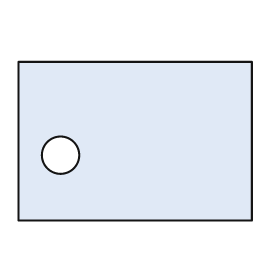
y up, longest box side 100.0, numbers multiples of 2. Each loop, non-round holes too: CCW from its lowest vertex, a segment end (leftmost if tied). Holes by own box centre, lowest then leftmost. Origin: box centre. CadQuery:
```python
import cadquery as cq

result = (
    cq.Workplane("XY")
    .moveTo(-50.0, -34.0)
    .lineTo(50.0, -34.0)
    .lineTo(50.0, 34.0)
    .lineTo(-50.0, 34.0)
    .close()
    .moveTo(-32.0, -6.0)
    .circle(8.0)
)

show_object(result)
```